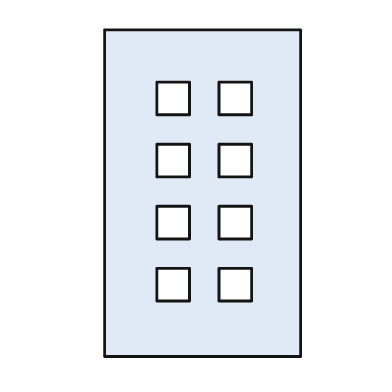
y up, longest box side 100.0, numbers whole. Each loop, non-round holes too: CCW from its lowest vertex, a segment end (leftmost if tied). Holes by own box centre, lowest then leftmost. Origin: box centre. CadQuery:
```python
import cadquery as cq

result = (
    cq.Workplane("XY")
    .moveTo(-30.0, -50.0)
    .lineTo(30.0, -50.0)
    .lineTo(30.0, 50.0)
    .lineTo(-30.0, 50.0)
    .close()
    .moveTo(-14.0, -33.0)
    .lineTo(-4.0, -33.0)
    .lineTo(-4.0, -23.0)
    .lineTo(-14.0, -23.0)
    .close()
    .moveTo(5.0, -33.0)
    .lineTo(15.0, -33.0)
    .lineTo(15.0, -23.0)
    .lineTo(5.0, -23.0)
    .close()
    .moveTo(-14.0, -14.0)
    .lineTo(-4.0, -14.0)
    .lineTo(-4.0, -4.0)
    .lineTo(-14.0, -4.0)
    .close()
    .moveTo(5.0, -14.0)
    .lineTo(15.0, -14.0)
    .lineTo(15.0, -4.0)
    .lineTo(5.0, -4.0)
    .close()
    .moveTo(-14.0, 5.0)
    .lineTo(-4.0, 5.0)
    .lineTo(-4.0, 15.0)
    .lineTo(-14.0, 15.0)
    .close()
    .moveTo(5.0, 5.0)
    .lineTo(15.0, 5.0)
    .lineTo(15.0, 15.0)
    .lineTo(5.0, 15.0)
    .close()
    .moveTo(-14.0, 24.0)
    .lineTo(-4.0, 24.0)
    .lineTo(-4.0, 34.0)
    .lineTo(-14.0, 34.0)
    .close()
    .moveTo(5.0, 24.0)
    .lineTo(15.0, 24.0)
    .lineTo(15.0, 34.0)
    .lineTo(5.0, 34.0)
    .close()
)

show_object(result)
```